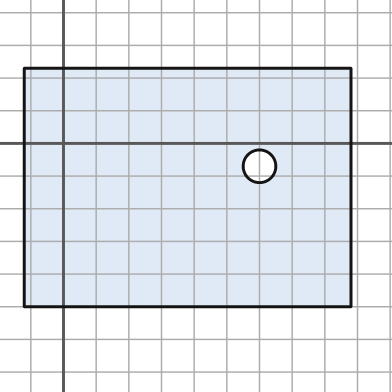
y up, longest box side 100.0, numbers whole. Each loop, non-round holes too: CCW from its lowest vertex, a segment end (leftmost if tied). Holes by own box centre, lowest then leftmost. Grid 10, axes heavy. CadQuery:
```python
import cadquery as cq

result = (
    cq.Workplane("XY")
    .moveTo(-12.0, -50.0)
    .lineTo(88.0, -50.0)
    .lineTo(88.0, 23.0)
    .lineTo(-12.0, 23.0)
    .close()
    .moveTo(60.0, -7.0)
    .circle(5.0)
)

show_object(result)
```